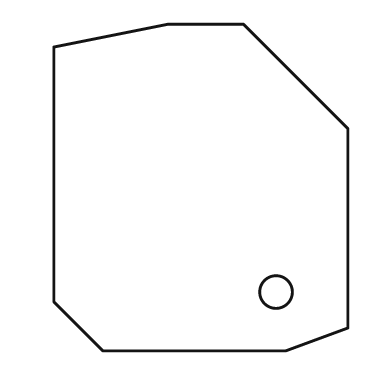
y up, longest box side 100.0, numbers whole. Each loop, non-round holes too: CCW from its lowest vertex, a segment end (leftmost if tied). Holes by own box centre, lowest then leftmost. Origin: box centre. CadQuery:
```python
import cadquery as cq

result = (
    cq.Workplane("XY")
    .moveTo(-30.0, -50.0)
    .lineTo(26.0, -50.0)
    .lineTo(45.0, -43.0)
    .lineTo(45.0, 18.0)
    .lineTo(13.0, 50.0)
    .lineTo(-10.0, 50.0)
    .lineTo(-45.0, 43.0)
    .lineTo(-45.0, -35.0)
    .close()
    .moveTo(23.0, -32.0)
    .circle(5.0)
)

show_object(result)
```